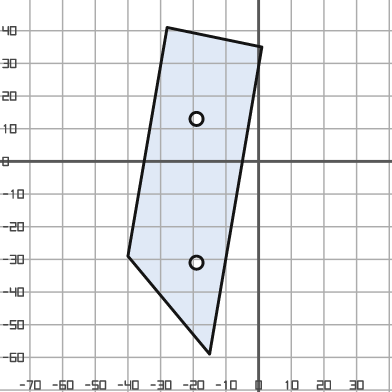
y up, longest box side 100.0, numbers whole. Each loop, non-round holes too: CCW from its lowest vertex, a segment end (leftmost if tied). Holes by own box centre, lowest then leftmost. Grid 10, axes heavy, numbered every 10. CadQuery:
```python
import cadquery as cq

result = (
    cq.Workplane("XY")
    .moveTo(-15.0, -59.0)
    .lineTo(1.0, 35.0)
    .lineTo(-28.0, 41.0)
    .lineTo(-40.0, -29.0)
    .close()
    .moveTo(-19.0, -31.0)
    .circle(2.0)
    .moveTo(-19.0, 13.0)
    .circle(2.0)
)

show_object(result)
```